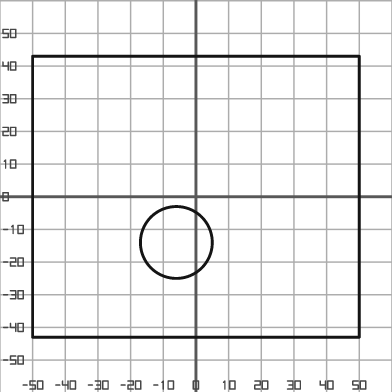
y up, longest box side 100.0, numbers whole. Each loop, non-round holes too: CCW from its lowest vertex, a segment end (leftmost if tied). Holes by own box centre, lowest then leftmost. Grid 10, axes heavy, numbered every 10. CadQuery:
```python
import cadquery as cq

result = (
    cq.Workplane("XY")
    .moveTo(-50.0, -43.0)
    .lineTo(50.0, -43.0)
    .lineTo(50.0, 43.0)
    .lineTo(-50.0, 43.0)
    .close()
    .moveTo(-6.0, -14.0)
    .circle(11.0)
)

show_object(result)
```